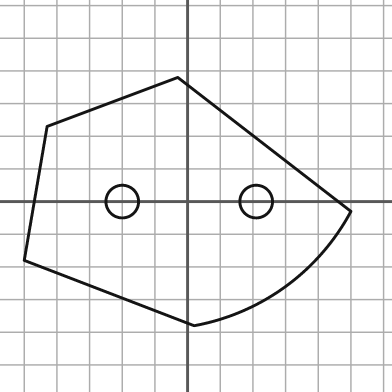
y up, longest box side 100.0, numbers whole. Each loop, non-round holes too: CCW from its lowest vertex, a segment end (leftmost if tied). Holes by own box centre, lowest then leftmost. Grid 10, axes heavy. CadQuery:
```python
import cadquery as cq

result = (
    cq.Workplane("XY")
    .moveTo(2.0, -38.0)
    .threePointArc((30.0, -26.0), (50.0, -3.0))
    .lineTo(-3.0, 38.0)
    .lineTo(-43.0, 23.0)
    .lineTo(-50.0, -18.0)
    .close()
    .moveTo(-20.0, 0.0)
    .circle(5.0)
    .moveTo(21.0, 0.0)
    .circle(5.0)
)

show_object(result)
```